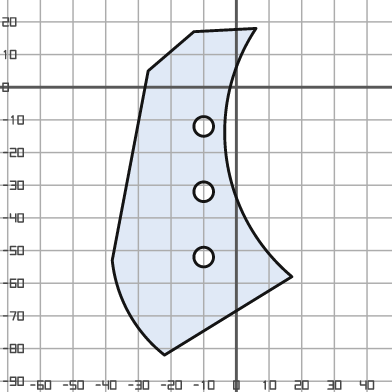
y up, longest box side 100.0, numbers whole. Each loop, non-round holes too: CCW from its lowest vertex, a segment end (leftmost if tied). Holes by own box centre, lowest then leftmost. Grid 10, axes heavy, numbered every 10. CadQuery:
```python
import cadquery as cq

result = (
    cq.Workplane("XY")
    .moveTo(-22.0, -82.0)
    .lineTo(17.0, -58.0)
    .threePointArc((-3.0, -22.0), (6.0, 18.0))
    .lineTo(-13.0, 17.0)
    .lineTo(-27.0, 5.0)
    .lineTo(-38.0, -53.0)
    .threePointArc((-33.0, -69.0), (-22.0, -82.0))
    .close()
    .moveTo(-10.0, -52.0)
    .circle(3.0)
    .moveTo(-10.0, -32.0)
    .circle(3.0)
    .moveTo(-10.0, -12.0)
    .circle(3.0)
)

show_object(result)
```